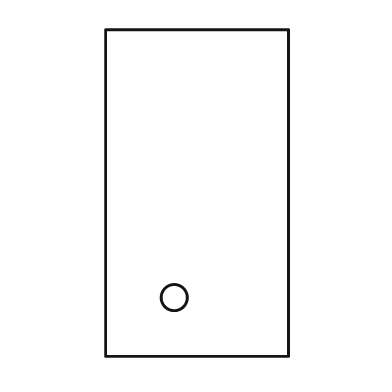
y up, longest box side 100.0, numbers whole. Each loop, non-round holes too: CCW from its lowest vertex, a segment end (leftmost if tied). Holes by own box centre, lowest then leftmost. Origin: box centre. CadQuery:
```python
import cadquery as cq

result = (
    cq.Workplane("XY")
    .moveTo(-28.0, -50.0)
    .lineTo(28.0, -50.0)
    .lineTo(28.0, 50.0)
    .lineTo(-28.0, 50.0)
    .close()
    .moveTo(-7.0, -32.0)
    .circle(4.0)
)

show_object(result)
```